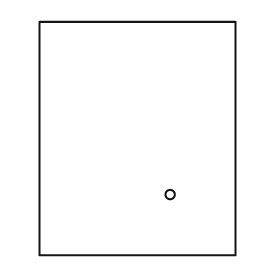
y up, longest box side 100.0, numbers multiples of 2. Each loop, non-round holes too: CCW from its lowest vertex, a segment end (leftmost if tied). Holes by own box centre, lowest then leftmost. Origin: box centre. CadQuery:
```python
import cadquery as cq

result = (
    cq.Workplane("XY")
    .moveTo(-42.0, -50.0)
    .lineTo(42.0, -50.0)
    .lineTo(42.0, 50.0)
    .lineTo(-42.0, 50.0)
    .close()
    .moveTo(14.0, -24.0)
    .circle(2.0)
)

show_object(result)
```